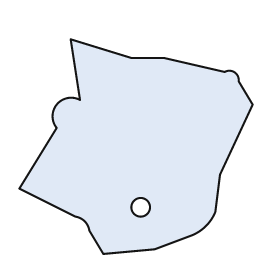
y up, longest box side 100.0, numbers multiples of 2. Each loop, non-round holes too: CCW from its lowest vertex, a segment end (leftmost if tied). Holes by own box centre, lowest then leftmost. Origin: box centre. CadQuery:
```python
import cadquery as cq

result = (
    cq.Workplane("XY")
    .moveTo(-14.0, -46.0)
    .lineTo(8.0, -44.0)
    .lineTo(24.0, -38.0)
    .threePointArc((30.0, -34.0), (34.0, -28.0))
    .lineTo(36.0, -12.0)
    .lineTo(50.0, 18.0)
    .lineTo(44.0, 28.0)
    .threePointArc((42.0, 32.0), (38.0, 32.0))
    .lineTo(12.0, 38.0)
    .lineTo(-2.0, 38.0)
    .lineTo(-28.0, 46.0)
    .lineTo(-24.0, 20.0)
    .threePointArc((-34.0, 18.0), (-34.0, 8.0))
    .lineTo(-50.0, -18.0)
    .lineTo(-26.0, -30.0)
    .threePointArc((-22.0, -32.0), (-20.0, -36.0))
    .close()
    .moveTo(2.0, -26.0)
    .circle(4.0)
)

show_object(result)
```